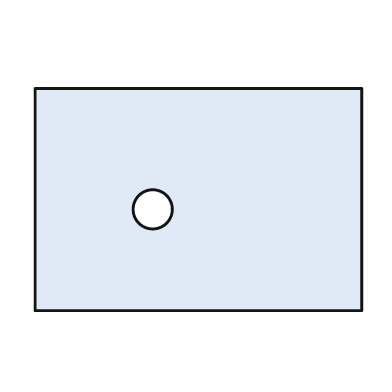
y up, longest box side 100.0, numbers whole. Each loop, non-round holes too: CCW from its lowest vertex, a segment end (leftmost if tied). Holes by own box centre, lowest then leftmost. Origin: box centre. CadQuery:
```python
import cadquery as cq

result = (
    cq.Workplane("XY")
    .moveTo(-50.0, -34.0)
    .lineTo(50.0, -34.0)
    .lineTo(50.0, 34.0)
    .lineTo(-50.0, 34.0)
    .close()
    .moveTo(-14.0, -3.0)
    .circle(6.0)
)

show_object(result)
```